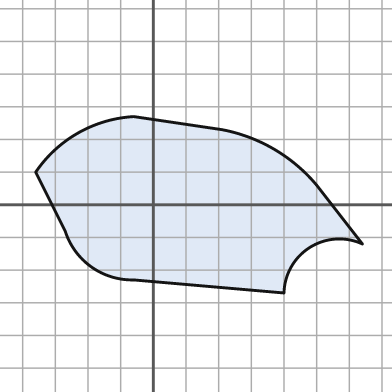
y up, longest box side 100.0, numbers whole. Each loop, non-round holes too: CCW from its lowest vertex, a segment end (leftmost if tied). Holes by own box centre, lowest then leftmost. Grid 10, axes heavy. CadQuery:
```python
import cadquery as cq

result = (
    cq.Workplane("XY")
    .moveTo(40.0, -27.0)
    .threePointArc((48.0, -13.0), (64.0, -12.0))
    .lineTo(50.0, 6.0)
    .threePointArc((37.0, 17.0), (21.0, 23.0))
    .lineTo(-6.0, 27.0)
    .threePointArc((-23.0, 22.0), (-36.0, 10.0))
    .lineTo(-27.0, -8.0)
    .threePointArc((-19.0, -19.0), (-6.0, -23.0))
    .close()
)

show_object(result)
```